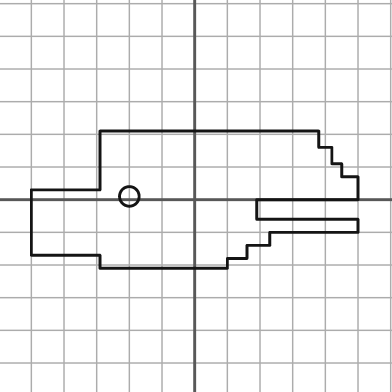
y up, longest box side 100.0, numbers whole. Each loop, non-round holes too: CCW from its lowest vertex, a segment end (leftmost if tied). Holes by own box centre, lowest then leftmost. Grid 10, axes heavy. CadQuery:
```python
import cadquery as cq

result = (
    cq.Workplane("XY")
    .moveTo(-29.0, -21.0)
    .lineTo(10.0, -21.0)
    .lineTo(10.0, -18.0)
    .lineTo(16.0, -18.0)
    .lineTo(16.0, -14.0)
    .lineTo(23.0, -14.0)
    .lineTo(23.0, -10.0)
    .lineTo(50.0, -10.0)
    .lineTo(50.0, -6.0)
    .lineTo(19.0, -6.0)
    .lineTo(19.0, 0.0)
    .lineTo(50.0, 0.0)
    .lineTo(50.0, 7.0)
    .lineTo(45.0, 7.0)
    .lineTo(45.0, 11.0)
    .lineTo(42.0, 11.0)
    .lineTo(42.0, 16.0)
    .lineTo(38.0, 16.0)
    .lineTo(38.0, 21.0)
    .lineTo(-29.0, 21.0)
    .lineTo(-29.0, 3.0)
    .lineTo(-50.0, 3.0)
    .lineTo(-50.0, -17.0)
    .lineTo(-29.0, -17.0)
    .close()
    .moveTo(-20.0, 1.0)
    .circle(3.0)
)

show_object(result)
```